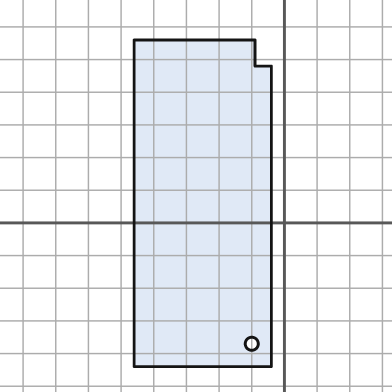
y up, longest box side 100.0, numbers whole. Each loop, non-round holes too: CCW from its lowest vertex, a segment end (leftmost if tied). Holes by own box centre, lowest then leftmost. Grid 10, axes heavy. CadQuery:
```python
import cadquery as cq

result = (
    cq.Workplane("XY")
    .moveTo(-46.0, -44.0)
    .lineTo(-4.0, -44.0)
    .lineTo(-4.0, 48.0)
    .lineTo(-9.0, 48.0)
    .lineTo(-9.0, 56.0)
    .lineTo(-46.0, 56.0)
    .close()
    .moveTo(-10.0, -37.0)
    .circle(2.0)
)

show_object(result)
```